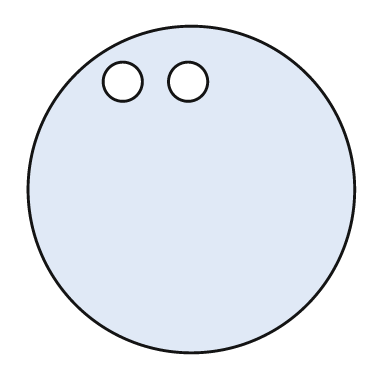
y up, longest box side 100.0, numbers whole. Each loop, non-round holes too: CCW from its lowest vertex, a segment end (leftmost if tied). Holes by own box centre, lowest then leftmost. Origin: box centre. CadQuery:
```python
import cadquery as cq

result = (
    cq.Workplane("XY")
    .moveTo(0.0, 0.0)
    .circle(50.0)
    .moveTo(-21.0, 33.0)
    .circle(6.0)
    .moveTo(-1.0, 33.0)
    .circle(6.0)
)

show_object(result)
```